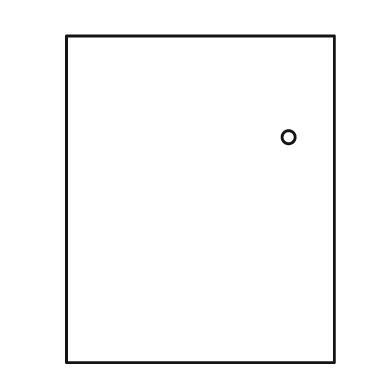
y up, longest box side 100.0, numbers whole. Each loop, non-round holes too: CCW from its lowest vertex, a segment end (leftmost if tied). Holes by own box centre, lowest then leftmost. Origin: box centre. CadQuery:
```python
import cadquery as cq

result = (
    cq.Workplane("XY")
    .moveTo(-41.0, -50.0)
    .lineTo(41.0, -50.0)
    .lineTo(41.0, 50.0)
    .lineTo(-41.0, 50.0)
    .close()
    .moveTo(27.0, 19.0)
    .circle(2.0)
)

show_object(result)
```